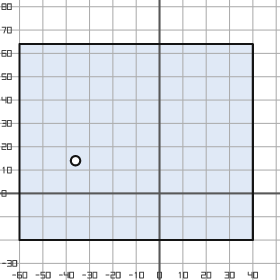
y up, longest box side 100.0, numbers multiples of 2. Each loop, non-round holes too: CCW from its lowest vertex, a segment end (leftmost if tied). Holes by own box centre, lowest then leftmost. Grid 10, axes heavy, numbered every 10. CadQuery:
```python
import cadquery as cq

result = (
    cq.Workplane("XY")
    .moveTo(-60.0, -20.0)
    .lineTo(40.0, -20.0)
    .lineTo(40.0, 64.0)
    .lineTo(-60.0, 64.0)
    .close()
    .moveTo(-36.0, 14.0)
    .circle(2.0)
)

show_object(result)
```